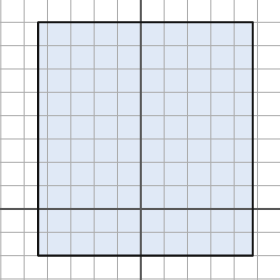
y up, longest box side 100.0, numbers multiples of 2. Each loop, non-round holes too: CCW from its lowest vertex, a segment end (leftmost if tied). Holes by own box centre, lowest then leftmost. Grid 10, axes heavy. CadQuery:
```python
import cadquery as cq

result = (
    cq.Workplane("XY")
    .moveTo(-44.0, -20.0)
    .lineTo(48.0, -20.0)
    .lineTo(48.0, 80.0)
    .lineTo(-44.0, 80.0)
    .close()
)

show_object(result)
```